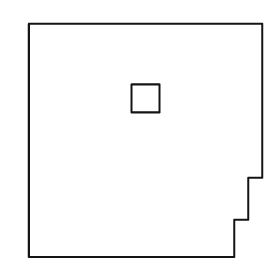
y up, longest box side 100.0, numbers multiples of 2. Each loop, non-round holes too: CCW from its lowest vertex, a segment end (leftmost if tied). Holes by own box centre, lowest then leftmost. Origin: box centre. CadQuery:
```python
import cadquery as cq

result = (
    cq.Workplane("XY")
    .moveTo(-50.0, -50.0)
    .lineTo(38.0, -50.0)
    .lineTo(38.0, -34.0)
    .lineTo(44.0, -34.0)
    .lineTo(44.0, -16.0)
    .lineTo(50.0, -16.0)
    .lineTo(50.0, 50.0)
    .lineTo(-50.0, 50.0)
    .close()
    .moveTo(-6.0, 12.0)
    .lineTo(6.0, 12.0)
    .lineTo(6.0, 24.0)
    .lineTo(-6.0, 24.0)
    .close()
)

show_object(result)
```